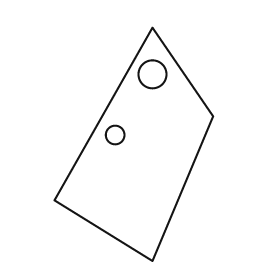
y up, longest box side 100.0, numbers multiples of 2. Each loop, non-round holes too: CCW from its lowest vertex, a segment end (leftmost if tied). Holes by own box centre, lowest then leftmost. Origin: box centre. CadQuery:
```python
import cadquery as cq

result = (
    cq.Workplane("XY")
    .moveTo(8.0, -50.0)
    .lineTo(34.0, 12.0)
    .lineTo(8.0, 50.0)
    .lineTo(-34.0, -24.0)
    .close()
    .moveTo(-8.0, 4.0)
    .circle(4.0)
    .moveTo(8.0, 30.0)
    .circle(6.0)
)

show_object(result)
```